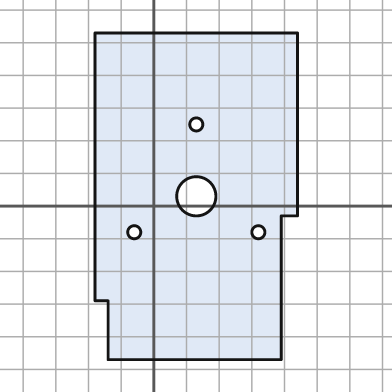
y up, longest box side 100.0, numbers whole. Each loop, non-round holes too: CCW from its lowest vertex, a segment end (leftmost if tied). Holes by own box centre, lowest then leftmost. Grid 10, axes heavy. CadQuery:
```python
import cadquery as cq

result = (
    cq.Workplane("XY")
    .moveTo(-14.0, -47.0)
    .lineTo(39.0, -47.0)
    .lineTo(39.0, -3.0)
    .lineTo(44.0, -3.0)
    .lineTo(44.0, 53.0)
    .lineTo(-18.0, 53.0)
    .lineTo(-18.0, -29.0)
    .lineTo(-14.0, -29.0)
    .close()
    .moveTo(-6.0, -8.0)
    .circle(2.0)
    .moveTo(32.0, -8.0)
    .circle(2.0)
    .moveTo(13.0, 3.0)
    .circle(6.0)
    .moveTo(13.0, 25.0)
    .circle(2.0)
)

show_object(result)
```